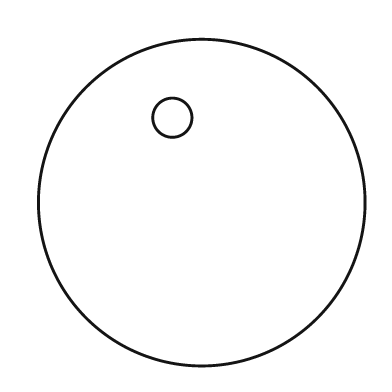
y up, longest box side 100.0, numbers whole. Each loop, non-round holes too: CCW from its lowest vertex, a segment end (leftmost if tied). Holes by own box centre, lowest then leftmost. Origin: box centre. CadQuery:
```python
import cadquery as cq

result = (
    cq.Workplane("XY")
    .moveTo(0.0, 0.0)
    .circle(50.0)
    .moveTo(-9.0, 26.0)
    .circle(6.0)
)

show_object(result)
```